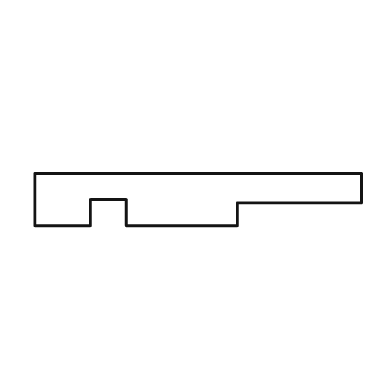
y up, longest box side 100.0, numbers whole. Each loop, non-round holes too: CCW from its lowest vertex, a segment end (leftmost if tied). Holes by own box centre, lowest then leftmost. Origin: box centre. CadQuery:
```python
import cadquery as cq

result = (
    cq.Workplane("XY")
    .moveTo(-50.0, -8.0)
    .lineTo(-33.0, -8.0)
    .lineTo(-33.0, 0.0)
    .lineTo(-22.0, 0.0)
    .lineTo(-22.0, -8.0)
    .lineTo(12.0, -8.0)
    .lineTo(12.0, -1.0)
    .lineTo(50.0, -1.0)
    .lineTo(50.0, 8.0)
    .lineTo(-50.0, 8.0)
    .close()
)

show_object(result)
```